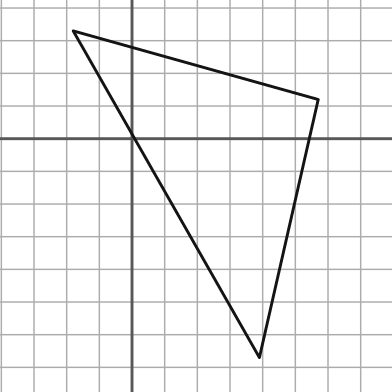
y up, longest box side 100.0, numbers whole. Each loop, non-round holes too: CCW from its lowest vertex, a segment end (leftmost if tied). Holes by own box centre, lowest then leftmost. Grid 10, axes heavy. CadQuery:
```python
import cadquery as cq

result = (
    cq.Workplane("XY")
    .moveTo(39.0, -67.0)
    .lineTo(57.0, 12.0)
    .lineTo(-18.0, 33.0)
    .close()
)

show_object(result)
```